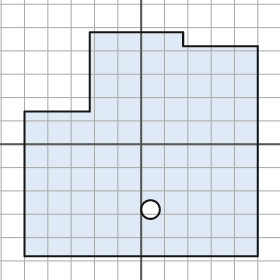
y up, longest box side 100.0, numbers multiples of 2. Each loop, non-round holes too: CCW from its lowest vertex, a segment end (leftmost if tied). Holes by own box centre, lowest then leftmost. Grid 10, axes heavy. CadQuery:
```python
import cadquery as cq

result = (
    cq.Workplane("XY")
    .moveTo(-50.0, -48.0)
    .lineTo(50.0, -48.0)
    .lineTo(50.0, 42.0)
    .lineTo(18.0, 42.0)
    .lineTo(18.0, 48.0)
    .lineTo(-22.0, 48.0)
    .lineTo(-22.0, 14.0)
    .lineTo(-50.0, 14.0)
    .close()
    .moveTo(4.0, -28.0)
    .circle(4.0)
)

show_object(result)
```